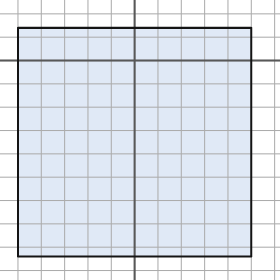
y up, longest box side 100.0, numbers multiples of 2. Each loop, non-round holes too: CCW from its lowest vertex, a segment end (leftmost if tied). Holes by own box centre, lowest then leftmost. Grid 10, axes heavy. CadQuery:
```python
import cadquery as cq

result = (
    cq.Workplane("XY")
    .moveTo(-50.0, -84.0)
    .lineTo(50.0, -84.0)
    .lineTo(50.0, 14.0)
    .lineTo(-50.0, 14.0)
    .close()
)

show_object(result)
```